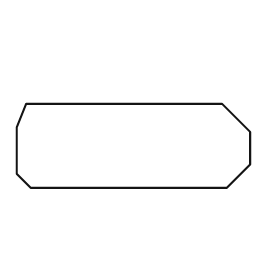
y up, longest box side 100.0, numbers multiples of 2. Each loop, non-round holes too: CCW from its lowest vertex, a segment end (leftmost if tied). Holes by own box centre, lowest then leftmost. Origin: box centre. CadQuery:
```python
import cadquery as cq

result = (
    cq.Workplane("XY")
    .moveTo(-44.0, -18.0)
    .lineTo(40.0, -18.0)
    .lineTo(50.0, -8.0)
    .lineTo(50.0, 6.0)
    .lineTo(38.0, 18.0)
    .lineTo(-46.0, 18.0)
    .lineTo(-50.0, 8.0)
    .lineTo(-50.0, -12.0)
    .close()
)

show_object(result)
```